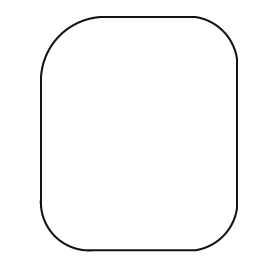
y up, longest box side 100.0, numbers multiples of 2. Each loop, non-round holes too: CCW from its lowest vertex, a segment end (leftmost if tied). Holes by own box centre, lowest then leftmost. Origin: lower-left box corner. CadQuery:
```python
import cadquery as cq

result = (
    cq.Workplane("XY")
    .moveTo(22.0, 0.0)
    .lineTo(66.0, 0.0)
    .threePointArc((78.0, 6.0), (84.0, 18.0))
    .lineTo(84.0, 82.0)
    .threePointArc((78.0, 94.0), (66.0, 100.0))
    .lineTo(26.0, 100.0)
    .threePointArc((8.0, 92.0), (0.0, 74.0))
    .lineTo(0.0, 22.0)
    .threePointArc((6.0, 6.0), (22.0, 0.0))
    .close()
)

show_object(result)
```